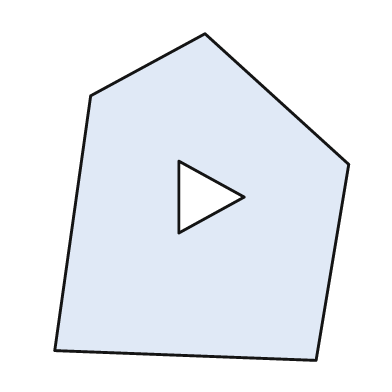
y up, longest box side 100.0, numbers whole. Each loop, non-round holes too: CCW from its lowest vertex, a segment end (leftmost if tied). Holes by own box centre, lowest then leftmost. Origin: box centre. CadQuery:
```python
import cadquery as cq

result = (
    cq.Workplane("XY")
    .moveTo(35.0, -50.0)
    .lineTo(45.0, 10.0)
    .lineTo(1.0, 50.0)
    .lineTo(-34.0, 31.0)
    .lineTo(-45.0, -47.0)
    .close()
    .moveTo(-7.0, -11.0)
    .lineTo(13.0, 0.0)
    .lineTo(-7.0, 11.0)
    .close()
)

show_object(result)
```